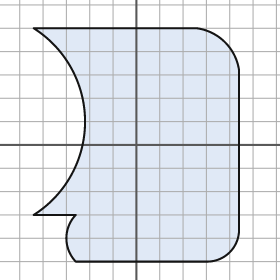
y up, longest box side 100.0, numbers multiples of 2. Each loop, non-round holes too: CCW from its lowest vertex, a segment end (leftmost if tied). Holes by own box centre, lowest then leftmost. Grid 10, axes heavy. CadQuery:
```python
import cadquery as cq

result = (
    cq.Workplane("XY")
    .moveTo(-26.0, -50.0)
    .lineTo(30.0, -50.0)
    .threePointArc((40.0, -46.0), (44.0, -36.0))
    .lineTo(44.0, 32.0)
    .threePointArc((38.0, 44.0), (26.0, 50.0))
    .lineTo(-44.0, 50.0)
    .threePointArc((-22.0, 10.0), (-44.0, -30.0))
    .lineTo(-26.0, -30.0)
    .threePointArc((-30.0, -40.0), (-26.0, -50.0))
    .close()
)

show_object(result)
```